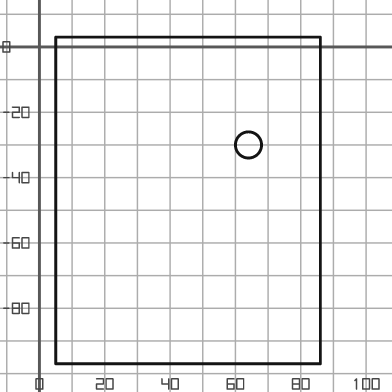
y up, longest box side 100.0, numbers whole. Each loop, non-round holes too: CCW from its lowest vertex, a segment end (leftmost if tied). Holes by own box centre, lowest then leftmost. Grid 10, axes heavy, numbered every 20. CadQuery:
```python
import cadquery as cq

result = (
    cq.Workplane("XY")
    .moveTo(5.0, -97.0)
    .lineTo(86.0, -97.0)
    .lineTo(86.0, 3.0)
    .lineTo(5.0, 3.0)
    .close()
    .moveTo(64.0, -30.0)
    .circle(4.0)
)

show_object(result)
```